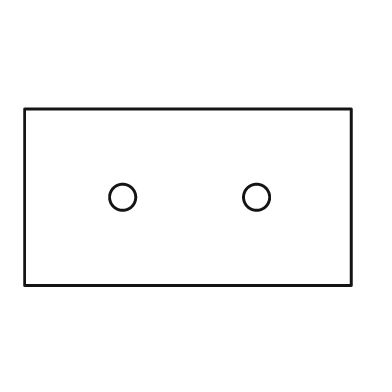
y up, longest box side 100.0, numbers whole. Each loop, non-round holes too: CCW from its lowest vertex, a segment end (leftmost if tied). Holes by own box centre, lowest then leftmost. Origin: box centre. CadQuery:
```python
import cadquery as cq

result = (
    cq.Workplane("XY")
    .moveTo(-50.0, -27.0)
    .lineTo(50.0, -27.0)
    .lineTo(50.0, 27.0)
    .lineTo(-50.0, 27.0)
    .close()
    .moveTo(-20.0, 0.0)
    .circle(4.0)
    .moveTo(21.0, 0.0)
    .circle(4.0)
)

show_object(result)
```